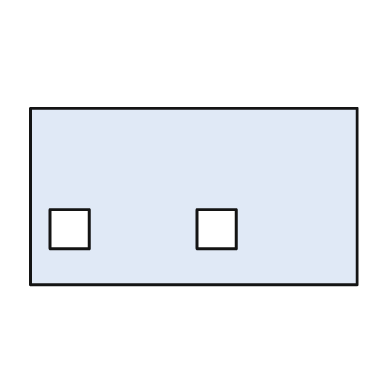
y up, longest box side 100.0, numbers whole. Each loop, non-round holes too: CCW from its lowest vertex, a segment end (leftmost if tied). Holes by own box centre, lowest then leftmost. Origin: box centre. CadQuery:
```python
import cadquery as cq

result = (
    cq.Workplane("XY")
    .moveTo(-50.0, -27.0)
    .lineTo(50.0, -27.0)
    .lineTo(50.0, 27.0)
    .lineTo(-50.0, 27.0)
    .close()
    .moveTo(-44.0, -16.0)
    .lineTo(-32.0, -16.0)
    .lineTo(-32.0, -4.0)
    .lineTo(-44.0, -4.0)
    .close()
    .moveTo(1.0, -16.0)
    .lineTo(13.0, -16.0)
    .lineTo(13.0, -4.0)
    .lineTo(1.0, -4.0)
    .close()
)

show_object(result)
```